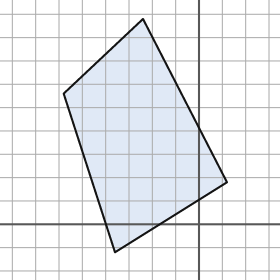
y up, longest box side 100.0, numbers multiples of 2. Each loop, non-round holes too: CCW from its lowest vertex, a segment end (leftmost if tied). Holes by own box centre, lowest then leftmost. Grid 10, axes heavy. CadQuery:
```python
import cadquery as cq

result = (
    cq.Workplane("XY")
    .moveTo(-36.0, -12.0)
    .lineTo(12.0, 18.0)
    .lineTo(-24.0, 88.0)
    .lineTo(-58.0, 56.0)
    .close()
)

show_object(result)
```